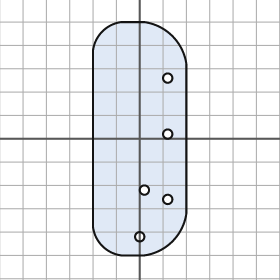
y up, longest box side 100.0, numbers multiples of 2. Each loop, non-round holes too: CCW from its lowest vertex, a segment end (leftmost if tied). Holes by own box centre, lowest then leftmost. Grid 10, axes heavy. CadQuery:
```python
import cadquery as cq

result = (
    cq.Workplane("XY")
    .moveTo(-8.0, -50.0)
    .lineTo(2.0, -50.0)
    .threePointArc((14.0, -44.0), (20.0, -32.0))
    .lineTo(20.0, 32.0)
    .threePointArc((14.0, 44.0), (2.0, 50.0))
    .lineTo(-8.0, 50.0)
    .threePointArc((-16.0, 46.0), (-20.0, 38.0))
    .lineTo(-20.0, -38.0)
    .threePointArc((-16.0, -46.0), (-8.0, -50.0))
    .close()
    .moveTo(0.0, -42.0)
    .circle(2.0)
    .moveTo(12.0, -26.0)
    .circle(2.0)
    .moveTo(2.0, -22.0)
    .circle(2.0)
    .moveTo(12.0, 2.0)
    .circle(2.0)
    .moveTo(12.0, 26.0)
    .circle(2.0)
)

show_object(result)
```